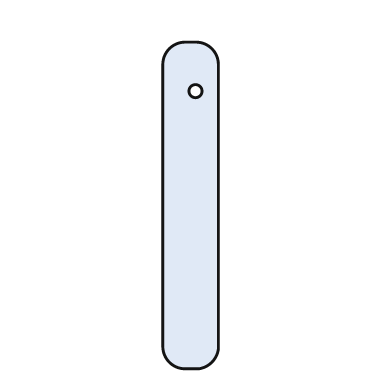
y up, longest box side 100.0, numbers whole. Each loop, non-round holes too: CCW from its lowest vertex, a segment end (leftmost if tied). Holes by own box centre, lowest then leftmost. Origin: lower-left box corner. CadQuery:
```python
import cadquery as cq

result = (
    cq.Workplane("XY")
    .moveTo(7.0, 0.0)
    .lineTo(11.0, 0.0)
    .threePointArc((15.0, 2.0), (17.0, 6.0))
    .lineTo(17.0, 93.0)
    .threePointArc((15.0, 98.0), (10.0, 100.0))
    .lineTo(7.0, 100.0)
    .threePointArc((2.0, 98.0), (0.0, 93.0))
    .lineTo(0.0, 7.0)
    .threePointArc((2.0, 2.0), (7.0, 0.0))
    .close()
    .moveTo(10.0, 85.0)
    .circle(2.0)
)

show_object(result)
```